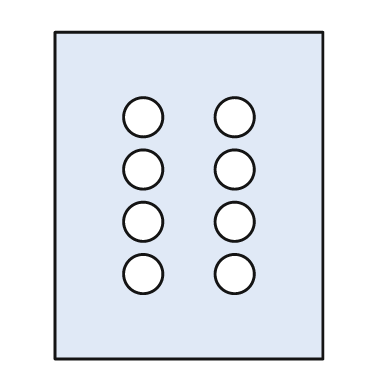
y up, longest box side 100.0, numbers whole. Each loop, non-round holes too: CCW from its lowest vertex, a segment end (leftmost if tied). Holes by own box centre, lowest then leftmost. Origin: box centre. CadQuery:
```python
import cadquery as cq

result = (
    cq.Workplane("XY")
    .moveTo(-41.0, -50.0)
    .lineTo(41.0, -50.0)
    .lineTo(41.0, 50.0)
    .lineTo(-41.0, 50.0)
    .close()
    .moveTo(-14.0, -24.0)
    .circle(6.0)
    .moveTo(14.0, -24.0)
    .circle(6.0)
    .moveTo(-14.0, -8.0)
    .circle(6.0)
    .moveTo(14.0, -8.0)
    .circle(6.0)
    .moveTo(-14.0, 8.0)
    .circle(6.0)
    .moveTo(14.0, 8.0)
    .circle(6.0)
    .moveTo(-14.0, 24.0)
    .circle(6.0)
    .moveTo(14.0, 24.0)
    .circle(6.0)
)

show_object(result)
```